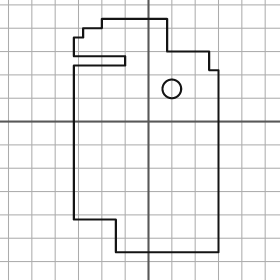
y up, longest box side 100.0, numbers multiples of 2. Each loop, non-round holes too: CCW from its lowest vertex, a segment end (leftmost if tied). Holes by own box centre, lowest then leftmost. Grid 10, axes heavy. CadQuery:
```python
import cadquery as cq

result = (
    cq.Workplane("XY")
    .moveTo(-14.0, -56.0)
    .lineTo(30.0, -56.0)
    .lineTo(30.0, 22.0)
    .lineTo(26.0, 22.0)
    .lineTo(26.0, 30.0)
    .lineTo(8.0, 30.0)
    .lineTo(8.0, 44.0)
    .lineTo(-20.0, 44.0)
    .lineTo(-20.0, 40.0)
    .lineTo(-28.0, 40.0)
    .lineTo(-28.0, 36.0)
    .lineTo(-32.0, 36.0)
    .lineTo(-32.0, 28.0)
    .lineTo(-10.0, 28.0)
    .lineTo(-10.0, 24.0)
    .lineTo(-32.0, 24.0)
    .lineTo(-32.0, -42.0)
    .lineTo(-14.0, -42.0)
    .close()
    .moveTo(10.0, 14.0)
    .circle(4.0)
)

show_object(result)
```